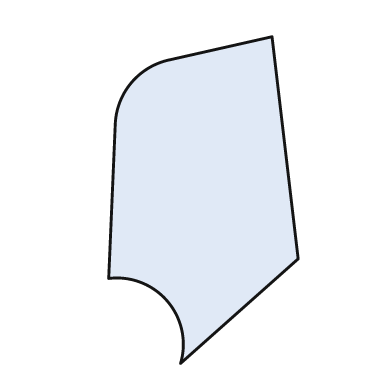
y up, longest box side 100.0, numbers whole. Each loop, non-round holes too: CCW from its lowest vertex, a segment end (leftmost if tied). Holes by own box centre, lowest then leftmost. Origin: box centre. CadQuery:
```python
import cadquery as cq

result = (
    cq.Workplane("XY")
    .moveTo(-7.0, -50.0)
    .lineTo(29.0, -18.0)
    .lineTo(21.0, 50.0)
    .lineTo(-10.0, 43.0)
    .threePointArc((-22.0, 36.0), (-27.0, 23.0))
    .lineTo(-29.0, -24.0)
    .threePointArc((-11.0, -31.0), (-7.0, -50.0))
    .close()
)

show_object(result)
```